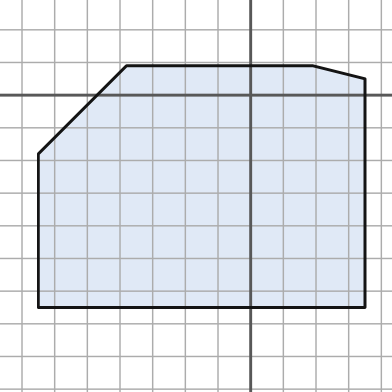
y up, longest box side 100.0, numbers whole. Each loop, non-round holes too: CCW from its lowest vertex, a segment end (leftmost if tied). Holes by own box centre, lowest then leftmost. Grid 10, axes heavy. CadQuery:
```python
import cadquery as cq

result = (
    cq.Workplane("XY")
    .moveTo(-65.0, -65.0)
    .lineTo(35.0, -65.0)
    .lineTo(35.0, 5.0)
    .lineTo(19.0, 9.0)
    .lineTo(-38.0, 9.0)
    .lineTo(-65.0, -18.0)
    .close()
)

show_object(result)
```